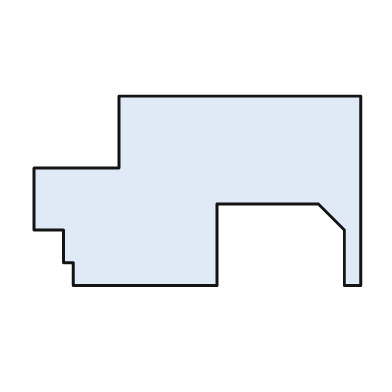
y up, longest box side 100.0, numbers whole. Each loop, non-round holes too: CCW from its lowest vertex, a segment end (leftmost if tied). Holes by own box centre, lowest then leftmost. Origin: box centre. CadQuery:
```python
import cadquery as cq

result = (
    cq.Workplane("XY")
    .moveTo(-38.0, -29.0)
    .lineTo(6.0, -29.0)
    .lineTo(6.0, -4.0)
    .lineTo(37.0, -4.0)
    .lineTo(45.0, -12.0)
    .lineTo(45.0, -29.0)
    .lineTo(50.0, -29.0)
    .lineTo(50.0, 29.0)
    .lineTo(-24.0, 29.0)
    .lineTo(-24.0, 7.0)
    .lineTo(-50.0, 7.0)
    .lineTo(-50.0, -12.0)
    .lineTo(-41.0, -12.0)
    .lineTo(-41.0, -22.0)
    .lineTo(-38.0, -22.0)
    .close()
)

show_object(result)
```